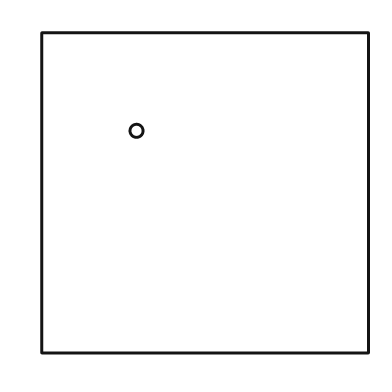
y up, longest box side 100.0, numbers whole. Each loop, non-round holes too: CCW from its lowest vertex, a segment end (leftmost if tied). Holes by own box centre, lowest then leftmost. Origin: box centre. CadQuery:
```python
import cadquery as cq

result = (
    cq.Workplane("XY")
    .moveTo(-50.0, -49.0)
    .lineTo(50.0, -49.0)
    .lineTo(50.0, 49.0)
    .lineTo(-50.0, 49.0)
    .close()
    .moveTo(-21.0, 19.0)
    .circle(2.0)
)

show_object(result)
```